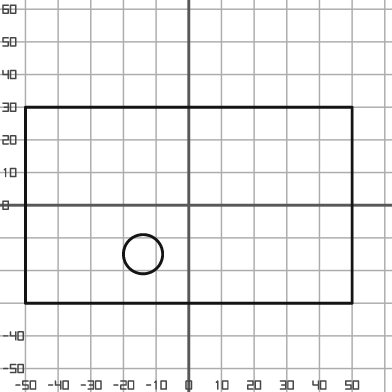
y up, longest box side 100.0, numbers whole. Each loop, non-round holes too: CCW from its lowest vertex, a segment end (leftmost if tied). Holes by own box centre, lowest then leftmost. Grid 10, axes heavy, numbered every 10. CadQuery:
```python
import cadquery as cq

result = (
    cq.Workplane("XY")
    .moveTo(-50.0, -30.0)
    .lineTo(50.0, -30.0)
    .lineTo(50.0, 30.0)
    .lineTo(-50.0, 30.0)
    .close()
    .moveTo(-14.0, -15.0)
    .circle(6.0)
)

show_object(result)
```